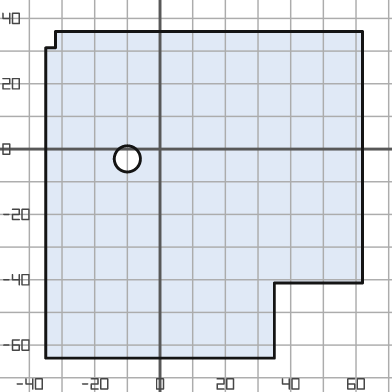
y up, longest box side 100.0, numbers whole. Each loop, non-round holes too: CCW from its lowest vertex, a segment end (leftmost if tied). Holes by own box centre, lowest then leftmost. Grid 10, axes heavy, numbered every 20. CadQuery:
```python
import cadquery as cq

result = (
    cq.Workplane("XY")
    .moveTo(-35.0, -64.0)
    .lineTo(35.0, -64.0)
    .lineTo(35.0, -41.0)
    .lineTo(62.0, -41.0)
    .lineTo(62.0, 36.0)
    .lineTo(-32.0, 36.0)
    .lineTo(-32.0, 31.0)
    .lineTo(-35.0, 31.0)
    .close()
    .moveTo(-10.0, -3.0)
    .circle(4.0)
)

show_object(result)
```